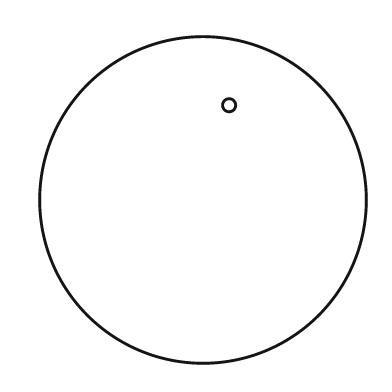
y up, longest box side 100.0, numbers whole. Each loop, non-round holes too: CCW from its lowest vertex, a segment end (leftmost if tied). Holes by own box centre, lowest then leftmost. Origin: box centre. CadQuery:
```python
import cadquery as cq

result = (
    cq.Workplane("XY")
    .moveTo(0.0, 0.0)
    .circle(50.0)
    .moveTo(8.0, 29.0)
    .circle(2.0)
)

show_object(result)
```